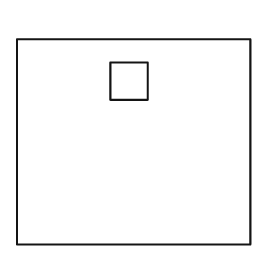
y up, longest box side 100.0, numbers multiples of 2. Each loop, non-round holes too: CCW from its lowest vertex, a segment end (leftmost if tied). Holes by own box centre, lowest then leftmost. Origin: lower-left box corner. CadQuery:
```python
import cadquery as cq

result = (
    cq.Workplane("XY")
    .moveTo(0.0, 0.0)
    .lineTo(100.0, 0.0)
    .lineTo(100.0, 88.0)
    .lineTo(0.0, 88.0)
    .close()
    .moveTo(40.0, 62.0)
    .lineTo(56.0, 62.0)
    .lineTo(56.0, 78.0)
    .lineTo(40.0, 78.0)
    .close()
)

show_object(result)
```